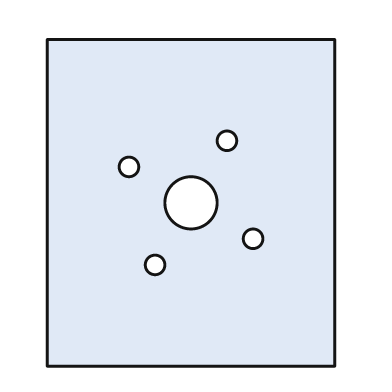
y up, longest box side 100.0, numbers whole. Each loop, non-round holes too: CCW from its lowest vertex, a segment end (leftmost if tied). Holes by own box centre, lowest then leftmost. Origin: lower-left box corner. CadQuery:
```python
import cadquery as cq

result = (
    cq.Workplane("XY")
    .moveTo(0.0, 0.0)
    .lineTo(88.0, 0.0)
    .lineTo(88.0, 100.0)
    .lineTo(0.0, 100.0)
    .close()
    .moveTo(33.0, 31.0)
    .circle(3.0)
    .moveTo(63.0, 39.0)
    .circle(3.0)
    .moveTo(44.0, 50.0)
    .circle(8.0)
    .moveTo(25.0, 61.0)
    .circle(3.0)
    .moveTo(55.0, 69.0)
    .circle(3.0)
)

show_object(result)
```